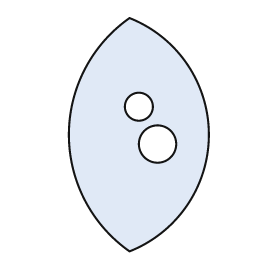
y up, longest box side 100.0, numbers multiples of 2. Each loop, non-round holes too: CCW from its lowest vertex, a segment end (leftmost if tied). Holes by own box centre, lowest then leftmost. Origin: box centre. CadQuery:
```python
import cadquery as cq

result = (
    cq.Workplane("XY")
    .moveTo(-4.0, -50.0)
    .threePointArc((30.0, 0.0), (-4.0, 50.0))
    .threePointArc((-30.0, 0.0), (-4.0, -50.0))
    .close()
    .moveTo(8.0, -4.0)
    .circle(8.0)
    .moveTo(0.0, 12.0)
    .circle(6.0)
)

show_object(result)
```